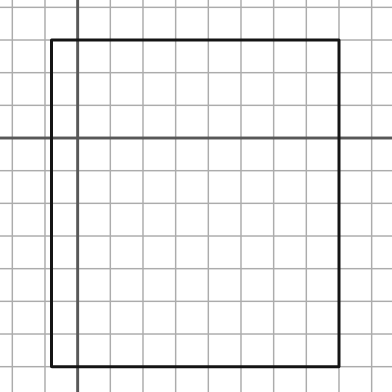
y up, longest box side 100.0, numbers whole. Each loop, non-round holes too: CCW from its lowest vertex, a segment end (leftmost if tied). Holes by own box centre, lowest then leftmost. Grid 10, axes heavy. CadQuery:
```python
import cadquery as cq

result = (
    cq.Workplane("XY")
    .moveTo(-8.0, -70.0)
    .lineTo(80.0, -70.0)
    .lineTo(80.0, 30.0)
    .lineTo(-8.0, 30.0)
    .close()
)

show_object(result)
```